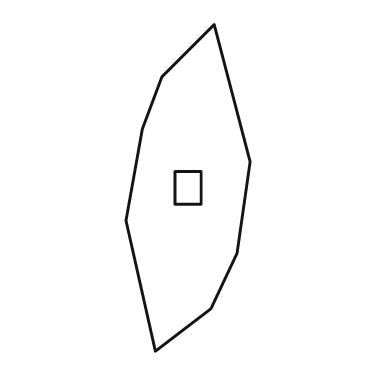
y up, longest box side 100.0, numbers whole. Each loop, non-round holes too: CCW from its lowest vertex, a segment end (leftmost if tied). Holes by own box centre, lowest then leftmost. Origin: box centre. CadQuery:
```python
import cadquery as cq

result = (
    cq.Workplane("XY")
    .moveTo(-10.0, -50.0)
    .lineTo(7.0, -37.0)
    .lineTo(15.0, -20.0)
    .lineTo(19.0, 8.0)
    .lineTo(8.0, 50.0)
    .lineTo(-8.0, 34.0)
    .lineTo(-14.0, 18.0)
    .lineTo(-19.0, -10.0)
    .close()
    .moveTo(-4.0, -5.0)
    .lineTo(4.0, -5.0)
    .lineTo(4.0, 5.0)
    .lineTo(-4.0, 5.0)
    .close()
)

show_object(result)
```